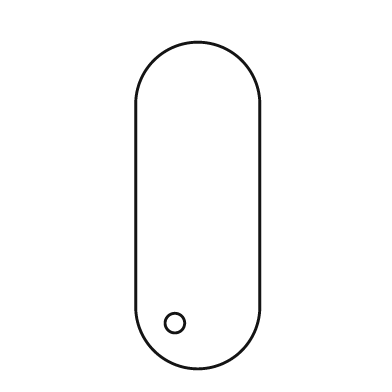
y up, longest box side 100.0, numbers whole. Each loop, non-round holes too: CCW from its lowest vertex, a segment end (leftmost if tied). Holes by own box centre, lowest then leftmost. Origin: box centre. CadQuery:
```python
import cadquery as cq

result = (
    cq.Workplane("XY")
    .moveTo(-19.0, -31.0)
    .threePointArc((0.0, -50.0), (19.0, -31.0))
    .lineTo(19.0, 31.0)
    .threePointArc((0.0, 50.0), (-19.0, 31.0))
    .close()
    .moveTo(-7.0, -36.0)
    .circle(3.0)
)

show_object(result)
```